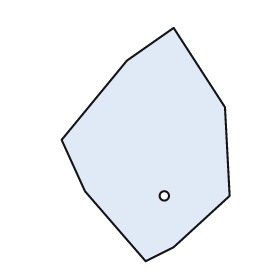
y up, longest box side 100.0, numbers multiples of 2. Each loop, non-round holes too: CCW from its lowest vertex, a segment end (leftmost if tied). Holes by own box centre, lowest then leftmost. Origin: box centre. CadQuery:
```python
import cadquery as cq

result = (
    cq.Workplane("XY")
    .moveTo(0.0, -50.0)
    .lineTo(12.0, -44.0)
    .lineTo(36.0, -22.0)
    .lineTo(34.0, 16.0)
    .lineTo(12.0, 50.0)
    .lineTo(-8.0, 36.0)
    .lineTo(-36.0, 2.0)
    .lineTo(-26.0, -20.0)
    .close()
    .moveTo(8.0, -22.0)
    .circle(2.0)
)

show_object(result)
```